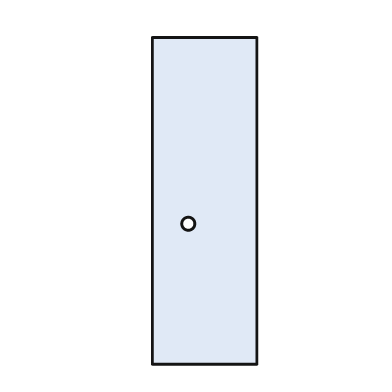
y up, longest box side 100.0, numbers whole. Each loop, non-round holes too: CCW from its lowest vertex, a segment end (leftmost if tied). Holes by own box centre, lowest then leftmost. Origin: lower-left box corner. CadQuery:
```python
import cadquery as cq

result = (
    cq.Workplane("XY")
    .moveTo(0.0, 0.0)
    .lineTo(32.0, 0.0)
    .lineTo(32.0, 100.0)
    .lineTo(0.0, 100.0)
    .close()
    .moveTo(11.0, 43.0)
    .circle(2.0)
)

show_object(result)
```